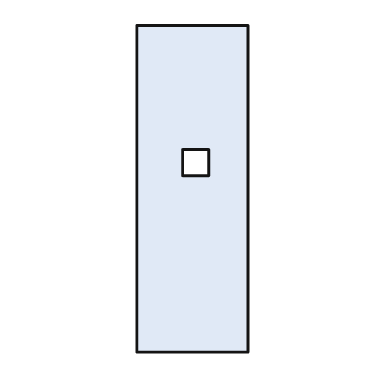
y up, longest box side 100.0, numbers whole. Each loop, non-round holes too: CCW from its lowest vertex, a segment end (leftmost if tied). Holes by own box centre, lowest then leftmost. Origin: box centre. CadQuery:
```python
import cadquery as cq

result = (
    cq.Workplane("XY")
    .moveTo(-17.0, -50.0)
    .lineTo(17.0, -50.0)
    .lineTo(17.0, 50.0)
    .lineTo(-17.0, 50.0)
    .close()
    .moveTo(-3.0, 4.0)
    .lineTo(5.0, 4.0)
    .lineTo(5.0, 12.0)
    .lineTo(-3.0, 12.0)
    .close()
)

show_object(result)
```